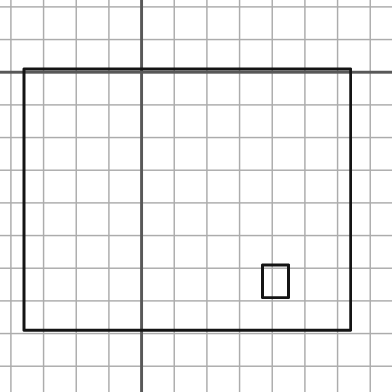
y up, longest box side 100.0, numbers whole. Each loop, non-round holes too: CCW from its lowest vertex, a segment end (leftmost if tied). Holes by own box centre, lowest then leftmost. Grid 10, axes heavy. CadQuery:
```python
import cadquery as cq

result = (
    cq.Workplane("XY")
    .moveTo(-36.0, -79.0)
    .lineTo(64.0, -79.0)
    .lineTo(64.0, 1.0)
    .lineTo(-36.0, 1.0)
    .close()
    .moveTo(37.0, -69.0)
    .lineTo(45.0, -69.0)
    .lineTo(45.0, -59.0)
    .lineTo(37.0, -59.0)
    .close()
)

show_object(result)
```